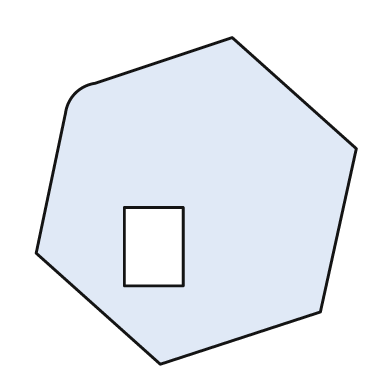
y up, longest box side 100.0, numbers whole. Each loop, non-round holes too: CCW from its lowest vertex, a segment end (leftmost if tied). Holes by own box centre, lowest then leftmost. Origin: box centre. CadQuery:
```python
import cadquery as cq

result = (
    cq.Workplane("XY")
    .moveTo(-11.0, -50.0)
    .lineTo(38.0, -34.0)
    .lineTo(49.0, 16.0)
    .lineTo(11.0, 50.0)
    .lineTo(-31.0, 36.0)
    .threePointArc((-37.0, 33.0), (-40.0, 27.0))
    .lineTo(-49.0, -16.0)
    .close()
    .moveTo(-22.0, -26.0)
    .lineTo(-4.0, -26.0)
    .lineTo(-4.0, -2.0)
    .lineTo(-22.0, -2.0)
    .close()
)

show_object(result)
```